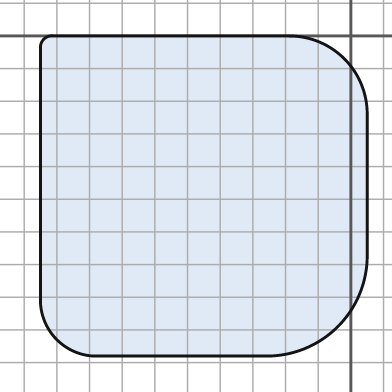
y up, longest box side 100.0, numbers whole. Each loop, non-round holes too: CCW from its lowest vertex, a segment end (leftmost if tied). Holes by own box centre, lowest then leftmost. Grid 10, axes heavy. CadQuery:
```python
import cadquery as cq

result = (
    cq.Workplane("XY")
    .moveTo(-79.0, -98.0)
    .lineTo(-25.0, -98.0)
    .threePointArc((-4.0, -89.0), (5.0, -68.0))
    .lineTo(5.0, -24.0)
    .threePointArc((-2.0, -7.0), (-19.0, 0.0))
    .lineTo(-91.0, 0.0)
    .threePointArc((-94.0, -1.0), (-95.0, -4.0))
    .lineTo(-95.0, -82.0)
    .threePointArc((-90.0, -93.0), (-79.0, -98.0))
    .close()
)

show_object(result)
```